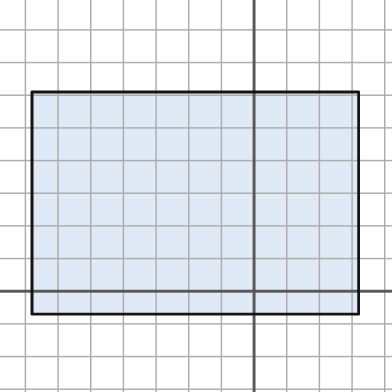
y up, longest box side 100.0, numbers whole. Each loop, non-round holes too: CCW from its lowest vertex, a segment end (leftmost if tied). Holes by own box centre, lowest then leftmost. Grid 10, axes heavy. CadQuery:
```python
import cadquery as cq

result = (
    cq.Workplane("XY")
    .moveTo(-68.0, -7.0)
    .lineTo(32.0, -7.0)
    .lineTo(32.0, 61.0)
    .lineTo(-68.0, 61.0)
    .close()
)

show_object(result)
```